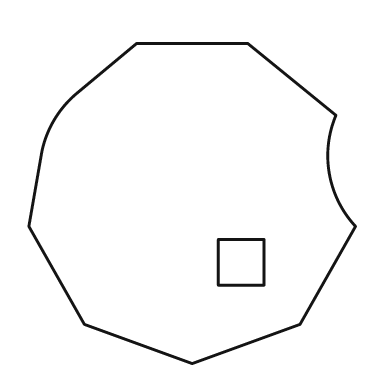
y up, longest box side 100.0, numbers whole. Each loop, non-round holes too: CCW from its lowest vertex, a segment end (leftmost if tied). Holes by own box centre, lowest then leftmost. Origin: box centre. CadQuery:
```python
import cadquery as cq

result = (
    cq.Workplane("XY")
    .moveTo(0.0, -49.0)
    .lineTo(33.0, -37.0)
    .lineTo(50.0, -7.0)
    .threePointArc((42.0, 9.0), (44.0, 27.0))
    .lineTo(17.0, 49.0)
    .lineTo(-17.0, 49.0)
    .lineTo(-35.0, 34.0)
    .threePointArc((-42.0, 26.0), (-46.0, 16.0))
    .lineTo(-50.0, -7.0)
    .lineTo(-33.0, -37.0)
    .close()
    .moveTo(8.0, -25.0)
    .lineTo(22.0, -25.0)
    .lineTo(22.0, -11.0)
    .lineTo(8.0, -11.0)
    .close()
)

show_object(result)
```